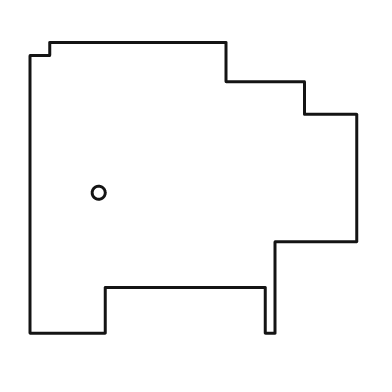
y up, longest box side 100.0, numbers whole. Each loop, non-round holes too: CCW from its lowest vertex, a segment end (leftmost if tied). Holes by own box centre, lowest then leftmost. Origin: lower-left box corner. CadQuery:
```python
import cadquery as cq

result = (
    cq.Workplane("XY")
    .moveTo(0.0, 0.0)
    .lineTo(23.0, 0.0)
    .lineTo(23.0, 14.0)
    .lineTo(72.0, 14.0)
    .lineTo(72.0, 0.0)
    .lineTo(75.0, 0.0)
    .lineTo(75.0, 28.0)
    .lineTo(100.0, 28.0)
    .lineTo(100.0, 67.0)
    .lineTo(84.0, 67.0)
    .lineTo(84.0, 77.0)
    .lineTo(60.0, 77.0)
    .lineTo(60.0, 89.0)
    .lineTo(6.0, 89.0)
    .lineTo(6.0, 85.0)
    .lineTo(0.0, 85.0)
    .close()
    .moveTo(21.0, 43.0)
    .circle(2.0)
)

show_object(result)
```